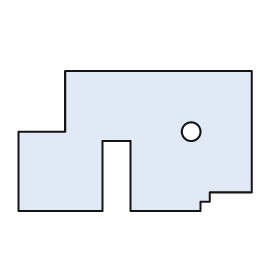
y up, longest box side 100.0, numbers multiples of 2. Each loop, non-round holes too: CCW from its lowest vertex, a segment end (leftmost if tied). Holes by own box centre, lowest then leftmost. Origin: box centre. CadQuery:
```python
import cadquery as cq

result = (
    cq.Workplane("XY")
    .moveTo(-50.0, -30.0)
    .lineTo(-14.0, -30.0)
    .lineTo(-14.0, 0.0)
    .lineTo(-2.0, 0.0)
    .lineTo(-2.0, -30.0)
    .lineTo(28.0, -30.0)
    .lineTo(28.0, -26.0)
    .lineTo(32.0, -26.0)
    .lineTo(32.0, -22.0)
    .lineTo(50.0, -22.0)
    .lineTo(50.0, 30.0)
    .lineTo(-30.0, 30.0)
    .lineTo(-30.0, 4.0)
    .lineTo(-50.0, 4.0)
    .close()
    .moveTo(24.0, 4.0)
    .circle(4.0)
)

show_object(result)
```